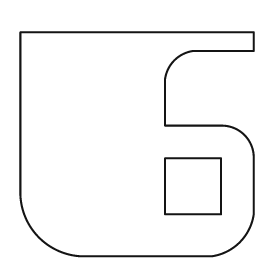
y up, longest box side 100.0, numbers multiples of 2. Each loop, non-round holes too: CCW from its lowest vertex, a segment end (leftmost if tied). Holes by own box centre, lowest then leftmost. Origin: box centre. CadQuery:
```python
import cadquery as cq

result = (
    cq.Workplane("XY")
    .moveTo(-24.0, -48.0)
    .lineTo(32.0, -48.0)
    .threePointArc((44.0, -42.0), (50.0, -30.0))
    .lineTo(50.0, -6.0)
    .threePointArc((46.0, 4.0), (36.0, 8.0))
    .lineTo(12.0, 8.0)
    .lineTo(12.0, 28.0)
    .threePointArc((16.0, 36.0), (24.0, 40.0))
    .lineTo(50.0, 40.0)
    .lineTo(50.0, 48.0)
    .lineTo(-50.0, 48.0)
    .lineTo(-50.0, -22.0)
    .threePointArc((-42.0, -40.0), (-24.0, -48.0))
    .close()
    .moveTo(12.0, -30.0)
    .lineTo(36.0, -30.0)
    .lineTo(36.0, -6.0)
    .lineTo(12.0, -6.0)
    .close()
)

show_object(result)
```